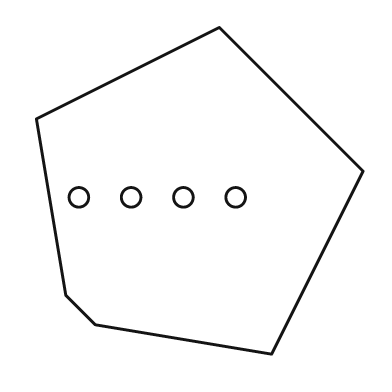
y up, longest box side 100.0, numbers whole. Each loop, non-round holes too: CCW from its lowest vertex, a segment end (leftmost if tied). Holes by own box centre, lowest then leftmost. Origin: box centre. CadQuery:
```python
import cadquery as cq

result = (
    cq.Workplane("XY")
    .moveTo(22.0, -50.0)
    .lineTo(50.0, 6.0)
    .lineTo(6.0, 50.0)
    .lineTo(-50.0, 22.0)
    .lineTo(-41.0, -32.0)
    .lineTo(-32.0, -41.0)
    .close()
    .moveTo(-37.0, -2.0)
    .circle(3.0)
    .moveTo(-21.0, -2.0)
    .circle(3.0)
    .moveTo(-5.0, -2.0)
    .circle(3.0)
    .moveTo(11.0, -2.0)
    .circle(3.0)
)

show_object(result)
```